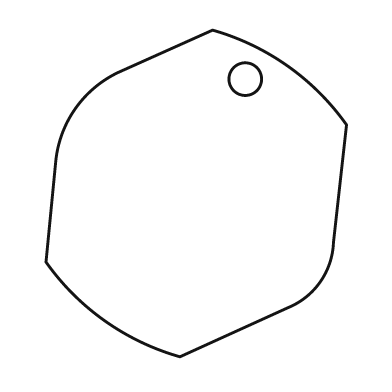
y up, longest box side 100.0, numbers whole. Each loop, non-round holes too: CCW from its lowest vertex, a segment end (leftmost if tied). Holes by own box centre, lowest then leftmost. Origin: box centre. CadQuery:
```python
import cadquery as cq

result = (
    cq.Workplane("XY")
    .moveTo(-5.0, -50.0)
    .lineTo(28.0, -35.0)
    .threePointArc((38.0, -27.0), (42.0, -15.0))
    .lineTo(46.0, 21.0)
    .threePointArc((28.0, 39.0), (5.0, 50.0))
    .lineTo(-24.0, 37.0)
    .threePointArc((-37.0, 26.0), (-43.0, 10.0))
    .lineTo(-46.0, -21.0)
    .threePointArc((-28.0, -39.0), (-5.0, -50.0))
    .close()
    .moveTo(15.0, 35.0)
    .circle(5.0)
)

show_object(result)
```